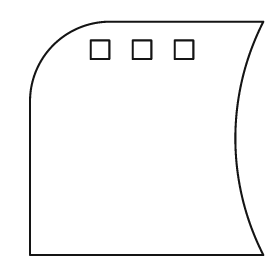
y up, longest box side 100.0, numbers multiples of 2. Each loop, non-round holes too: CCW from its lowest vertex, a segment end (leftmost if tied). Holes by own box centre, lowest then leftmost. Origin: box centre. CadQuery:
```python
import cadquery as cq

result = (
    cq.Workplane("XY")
    .moveTo(-50.0, -50.0)
    .lineTo(50.0, -50.0)
    .threePointArc((38.0, 0.0), (50.0, 50.0))
    .lineTo(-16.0, 50.0)
    .threePointArc((-40.0, 40.0), (-50.0, 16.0))
    .close()
    .moveTo(-24.0, 34.0)
    .lineTo(-16.0, 34.0)
    .lineTo(-16.0, 42.0)
    .lineTo(-24.0, 42.0)
    .close()
    .moveTo(-6.0, 34.0)
    .lineTo(2.0, 34.0)
    .lineTo(2.0, 42.0)
    .lineTo(-6.0, 42.0)
    .close()
    .moveTo(12.0, 34.0)
    .lineTo(20.0, 34.0)
    .lineTo(20.0, 42.0)
    .lineTo(12.0, 42.0)
    .close()
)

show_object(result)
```